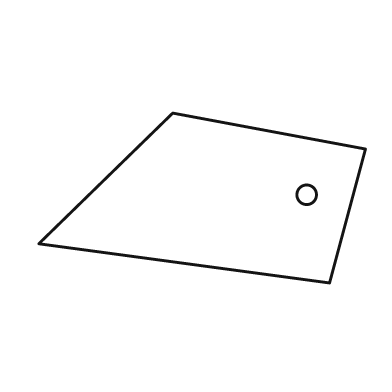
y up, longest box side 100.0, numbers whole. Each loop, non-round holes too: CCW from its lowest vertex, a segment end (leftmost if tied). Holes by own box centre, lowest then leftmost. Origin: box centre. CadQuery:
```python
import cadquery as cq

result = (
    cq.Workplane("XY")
    .moveTo(39.0, -26.0)
    .lineTo(50.0, 15.0)
    .lineTo(-9.0, 26.0)
    .lineTo(-50.0, -14.0)
    .close()
    .moveTo(32.0, 1.0)
    .circle(3.0)
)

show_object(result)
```